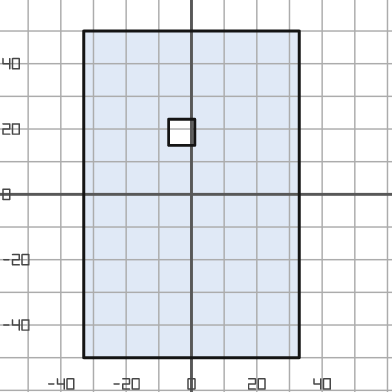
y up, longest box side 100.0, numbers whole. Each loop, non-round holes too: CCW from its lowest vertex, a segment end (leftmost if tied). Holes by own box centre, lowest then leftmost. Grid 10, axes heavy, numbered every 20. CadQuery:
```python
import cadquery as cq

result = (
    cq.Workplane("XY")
    .moveTo(-33.0, -50.0)
    .lineTo(33.0, -50.0)
    .lineTo(33.0, 50.0)
    .lineTo(-33.0, 50.0)
    .close()
    .moveTo(-7.0, 15.0)
    .lineTo(1.0, 15.0)
    .lineTo(1.0, 23.0)
    .lineTo(-7.0, 23.0)
    .close()
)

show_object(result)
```